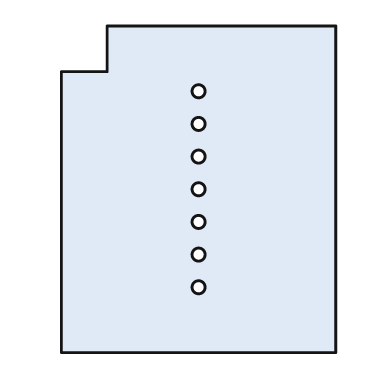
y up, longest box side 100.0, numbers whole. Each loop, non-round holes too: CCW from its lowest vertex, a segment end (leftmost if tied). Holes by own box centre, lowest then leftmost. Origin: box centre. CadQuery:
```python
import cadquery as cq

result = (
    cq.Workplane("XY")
    .moveTo(-42.0, -50.0)
    .lineTo(42.0, -50.0)
    .lineTo(42.0, 50.0)
    .lineTo(-28.0, 50.0)
    .lineTo(-28.0, 36.0)
    .lineTo(-42.0, 36.0)
    .close()
    .moveTo(0.0, -30.0)
    .circle(2.0)
    .moveTo(0.0, -20.0)
    .circle(2.0)
    .moveTo(0.0, -10.0)
    .circle(2.0)
    .moveTo(0.0, 0.0)
    .circle(2.0)
    .moveTo(0.0, 10.0)
    .circle(2.0)
    .moveTo(0.0, 20.0)
    .circle(2.0)
    .moveTo(0.0, 30.0)
    .circle(2.0)
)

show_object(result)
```